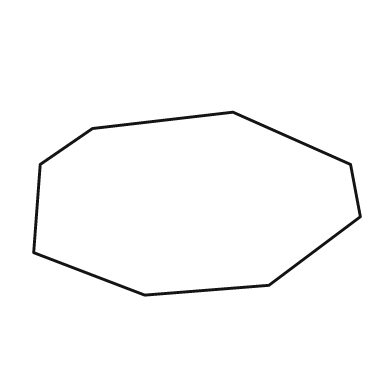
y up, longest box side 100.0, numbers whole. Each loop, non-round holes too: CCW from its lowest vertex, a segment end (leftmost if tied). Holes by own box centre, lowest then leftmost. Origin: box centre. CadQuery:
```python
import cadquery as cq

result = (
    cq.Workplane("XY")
    .moveTo(-16.0, -28.0)
    .lineTo(22.0, -25.0)
    .lineTo(50.0, -4.0)
    .lineTo(47.0, 12.0)
    .lineTo(11.0, 28.0)
    .lineTo(-32.0, 23.0)
    .lineTo(-48.0, 12.0)
    .lineTo(-50.0, -15.0)
    .close()
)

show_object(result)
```